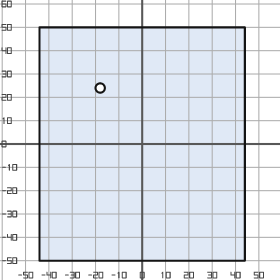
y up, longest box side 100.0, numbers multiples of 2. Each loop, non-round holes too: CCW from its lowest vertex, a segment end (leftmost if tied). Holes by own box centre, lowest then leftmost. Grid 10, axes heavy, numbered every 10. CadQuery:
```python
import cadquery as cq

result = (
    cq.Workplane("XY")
    .moveTo(-44.0, -50.0)
    .lineTo(44.0, -50.0)
    .lineTo(44.0, 50.0)
    .lineTo(-44.0, 50.0)
    .close()
    .moveTo(-18.0, 24.0)
    .circle(2.0)
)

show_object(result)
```